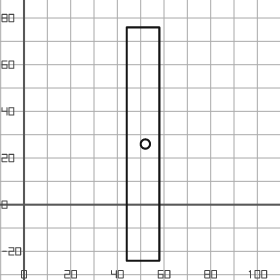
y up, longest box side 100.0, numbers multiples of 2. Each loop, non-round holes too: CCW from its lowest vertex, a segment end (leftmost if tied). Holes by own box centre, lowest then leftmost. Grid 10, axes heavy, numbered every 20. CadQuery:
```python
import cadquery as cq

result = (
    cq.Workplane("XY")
    .moveTo(44.0, -24.0)
    .lineTo(58.0, -24.0)
    .lineTo(58.0, 76.0)
    .lineTo(44.0, 76.0)
    .close()
    .moveTo(52.0, 26.0)
    .circle(2.0)
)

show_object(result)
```